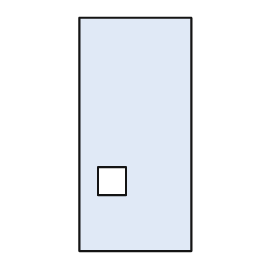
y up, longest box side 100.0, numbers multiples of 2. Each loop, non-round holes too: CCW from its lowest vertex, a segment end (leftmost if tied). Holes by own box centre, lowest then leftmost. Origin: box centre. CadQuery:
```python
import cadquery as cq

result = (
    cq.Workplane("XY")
    .moveTo(-24.0, -50.0)
    .lineTo(24.0, -50.0)
    .lineTo(24.0, 50.0)
    .lineTo(-24.0, 50.0)
    .close()
    .moveTo(-16.0, -26.0)
    .lineTo(-4.0, -26.0)
    .lineTo(-4.0, -14.0)
    .lineTo(-16.0, -14.0)
    .close()
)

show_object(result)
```